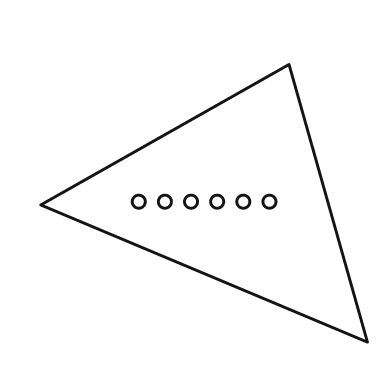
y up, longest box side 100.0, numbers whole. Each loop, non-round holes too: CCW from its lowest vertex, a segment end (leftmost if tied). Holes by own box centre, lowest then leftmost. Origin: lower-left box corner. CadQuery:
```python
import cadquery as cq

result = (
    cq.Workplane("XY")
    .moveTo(100.0, 0.0)
    .lineTo(76.0, 85.0)
    .lineTo(0.0, 42.0)
    .close()
    .moveTo(30.0, 43.0)
    .circle(2.0)
    .moveTo(38.0, 43.0)
    .circle(2.0)
    .moveTo(46.0, 43.0)
    .circle(2.0)
    .moveTo(54.0, 43.0)
    .circle(2.0)
    .moveTo(62.0, 43.0)
    .circle(2.0)
    .moveTo(70.0, 43.0)
    .circle(2.0)
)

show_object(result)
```